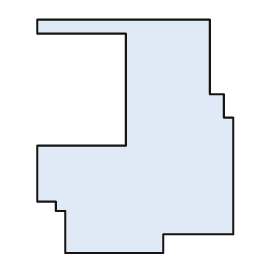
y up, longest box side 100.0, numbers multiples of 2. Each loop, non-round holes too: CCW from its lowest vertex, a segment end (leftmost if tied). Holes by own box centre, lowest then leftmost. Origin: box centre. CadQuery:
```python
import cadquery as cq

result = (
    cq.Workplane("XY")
    .moveTo(-30.0, -50.0)
    .lineTo(12.0, -50.0)
    .lineTo(12.0, -42.0)
    .lineTo(42.0, -42.0)
    .lineTo(42.0, 8.0)
    .lineTo(38.0, 8.0)
    .lineTo(38.0, 18.0)
    .lineTo(32.0, 18.0)
    .lineTo(32.0, 50.0)
    .lineTo(-42.0, 50.0)
    .lineTo(-42.0, 44.0)
    .lineTo(-4.0, 44.0)
    .lineTo(-4.0, -4.0)
    .lineTo(-42.0, -4.0)
    .lineTo(-42.0, -28.0)
    .lineTo(-34.0, -28.0)
    .lineTo(-34.0, -32.0)
    .lineTo(-30.0, -32.0)
    .close()
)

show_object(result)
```